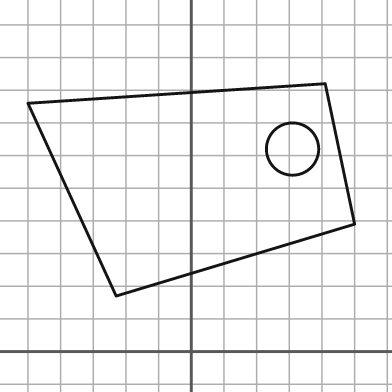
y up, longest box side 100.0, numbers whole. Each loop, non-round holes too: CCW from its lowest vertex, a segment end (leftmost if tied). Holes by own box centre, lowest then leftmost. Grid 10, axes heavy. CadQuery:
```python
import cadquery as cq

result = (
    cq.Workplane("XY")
    .moveTo(-23.0, 17.0)
    .lineTo(50.0, 39.0)
    .lineTo(41.0, 82.0)
    .lineTo(-50.0, 76.0)
    .close()
    .moveTo(31.0, 62.0)
    .circle(8.0)
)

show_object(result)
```